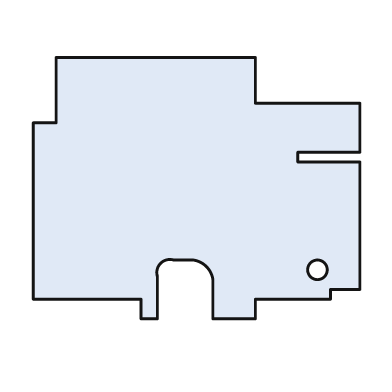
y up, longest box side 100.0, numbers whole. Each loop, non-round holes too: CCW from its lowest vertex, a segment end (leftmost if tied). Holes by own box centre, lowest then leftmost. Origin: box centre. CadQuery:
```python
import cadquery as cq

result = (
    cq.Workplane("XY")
    .moveTo(-17.0, -40.0)
    .lineTo(-12.0, -40.0)
    .lineTo(-12.0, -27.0)
    .threePointArc((-11.0, -23.0), (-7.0, -22.0))
    .lineTo(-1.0, -22.0)
    .threePointArc((3.0, -24.0), (5.0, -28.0))
    .lineTo(5.0, -40.0)
    .lineTo(18.0, -40.0)
    .lineTo(18.0, -34.0)
    .lineTo(41.0, -34.0)
    .lineTo(41.0, -31.0)
    .lineTo(50.0, -31.0)
    .lineTo(50.0, 8.0)
    .lineTo(31.0, 8.0)
    .lineTo(31.0, 11.0)
    .lineTo(50.0, 11.0)
    .lineTo(50.0, 26.0)
    .lineTo(18.0, 26.0)
    .lineTo(18.0, 40.0)
    .lineTo(-43.0, 40.0)
    .lineTo(-43.0, 20.0)
    .lineTo(-50.0, 20.0)
    .lineTo(-50.0, -34.0)
    .lineTo(-17.0, -34.0)
    .close()
    .moveTo(37.0, -25.0)
    .circle(3.0)
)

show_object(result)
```